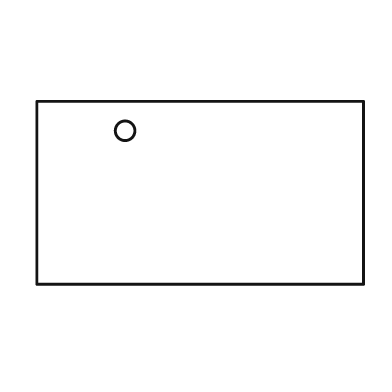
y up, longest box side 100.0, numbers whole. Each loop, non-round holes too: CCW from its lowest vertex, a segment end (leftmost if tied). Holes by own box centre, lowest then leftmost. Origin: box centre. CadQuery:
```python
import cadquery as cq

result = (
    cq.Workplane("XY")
    .moveTo(-50.0, -28.0)
    .lineTo(50.0, -28.0)
    .lineTo(50.0, 28.0)
    .lineTo(-50.0, 28.0)
    .close()
    .moveTo(-23.0, 19.0)
    .circle(3.0)
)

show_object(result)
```